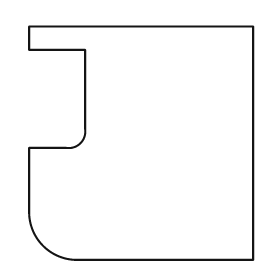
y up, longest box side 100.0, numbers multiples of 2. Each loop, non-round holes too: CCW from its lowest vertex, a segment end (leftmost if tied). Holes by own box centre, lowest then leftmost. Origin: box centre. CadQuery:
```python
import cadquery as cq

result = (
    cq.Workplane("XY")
    .moveTo(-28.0, -50.0)
    .lineTo(48.0, -50.0)
    .lineTo(48.0, 50.0)
    .lineTo(-48.0, 50.0)
    .lineTo(-48.0, 40.0)
    .lineTo(-24.0, 40.0)
    .lineTo(-24.0, 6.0)
    .threePointArc((-26.0, 0.0), (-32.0, -2.0))
    .lineTo(-48.0, -2.0)
    .lineTo(-48.0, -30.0)
    .threePointArc((-42.0, -44.0), (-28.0, -50.0))
    .close()
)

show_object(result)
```